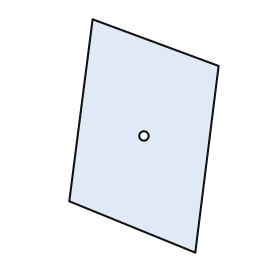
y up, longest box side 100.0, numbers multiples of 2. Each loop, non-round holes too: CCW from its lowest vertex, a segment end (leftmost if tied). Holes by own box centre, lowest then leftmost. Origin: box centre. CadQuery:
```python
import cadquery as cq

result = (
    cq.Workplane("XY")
    .moveTo(22.0, -50.0)
    .lineTo(32.0, 30.0)
    .lineTo(-22.0, 50.0)
    .lineTo(-32.0, -28.0)
    .close()
    .moveTo(0.0, 0.0)
    .circle(2.0)
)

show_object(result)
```